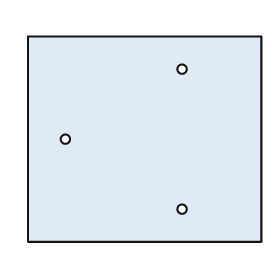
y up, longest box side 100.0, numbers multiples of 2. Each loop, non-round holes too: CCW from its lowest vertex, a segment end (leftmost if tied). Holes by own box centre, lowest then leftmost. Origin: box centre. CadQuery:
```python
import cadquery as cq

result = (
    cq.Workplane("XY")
    .moveTo(-50.0, -44.0)
    .lineTo(50.0, -44.0)
    .lineTo(50.0, 44.0)
    .lineTo(-50.0, 44.0)
    .close()
    .moveTo(16.0, -30.0)
    .circle(2.0)
    .moveTo(-34.0, 0.0)
    .circle(2.0)
    .moveTo(16.0, 30.0)
    .circle(2.0)
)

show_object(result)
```